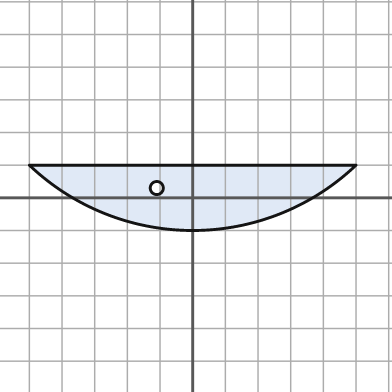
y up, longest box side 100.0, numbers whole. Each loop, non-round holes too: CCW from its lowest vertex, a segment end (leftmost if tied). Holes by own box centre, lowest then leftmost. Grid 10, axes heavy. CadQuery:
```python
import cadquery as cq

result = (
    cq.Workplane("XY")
    .moveTo(-50.0, 10.0)
    .threePointArc((0.0, -10.0), (50.0, 10.0))
    .close()
    .moveTo(-11.0, 3.0)
    .circle(2.0)
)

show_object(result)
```